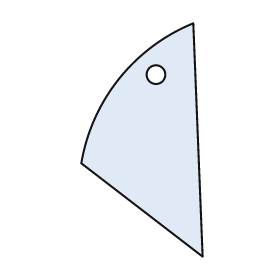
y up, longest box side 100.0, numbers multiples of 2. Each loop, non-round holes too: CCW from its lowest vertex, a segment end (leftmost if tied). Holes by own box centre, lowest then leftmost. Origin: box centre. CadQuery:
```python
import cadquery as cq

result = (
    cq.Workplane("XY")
    .moveTo(26.0, -50.0)
    .lineTo(22.0, 50.0)
    .threePointArc((-10.0, 26.0), (-26.0, -10.0))
    .close()
    .moveTo(6.0, 28.0)
    .circle(4.0)
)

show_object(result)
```